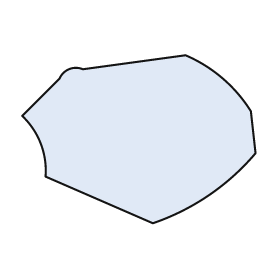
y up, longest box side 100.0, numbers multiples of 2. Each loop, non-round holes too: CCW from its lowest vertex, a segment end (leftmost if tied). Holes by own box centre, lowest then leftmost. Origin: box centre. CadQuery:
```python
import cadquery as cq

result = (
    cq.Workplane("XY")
    .moveTo(6.0, -36.0)
    .threePointArc((30.0, -24.0), (50.0, -6.0))
    .lineTo(48.0, 12.0)
    .threePointArc((36.0, 26.0), (20.0, 36.0))
    .lineTo(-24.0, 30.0)
    .threePointArc((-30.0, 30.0), (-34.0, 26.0))
    .lineTo(-50.0, 10.0)
    .threePointArc((-42.0, -2.0), (-40.0, -16.0))
    .close()
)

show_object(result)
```